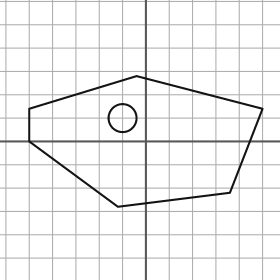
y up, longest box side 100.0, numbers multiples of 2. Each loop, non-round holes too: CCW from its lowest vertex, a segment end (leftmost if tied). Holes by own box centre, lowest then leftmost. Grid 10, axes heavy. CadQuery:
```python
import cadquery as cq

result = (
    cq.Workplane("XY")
    .moveTo(-12.0, -28.0)
    .lineTo(36.0, -22.0)
    .lineTo(50.0, 14.0)
    .lineTo(-4.0, 28.0)
    .lineTo(-50.0, 14.0)
    .lineTo(-50.0, 0.0)
    .close()
    .moveTo(-10.0, 10.0)
    .circle(6.0)
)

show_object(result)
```